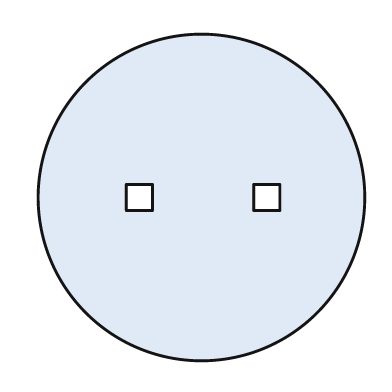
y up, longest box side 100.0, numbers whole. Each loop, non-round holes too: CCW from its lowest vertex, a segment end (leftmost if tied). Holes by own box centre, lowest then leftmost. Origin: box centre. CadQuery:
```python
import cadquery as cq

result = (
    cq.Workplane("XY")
    .moveTo(0.0, 0.0)
    .circle(50.0)
    .moveTo(-23.0, -4.0)
    .lineTo(-15.0, -4.0)
    .lineTo(-15.0, 4.0)
    .lineTo(-23.0, 4.0)
    .close()
    .moveTo(16.0, -4.0)
    .lineTo(24.0, -4.0)
    .lineTo(24.0, 4.0)
    .lineTo(16.0, 4.0)
    .close()
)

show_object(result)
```